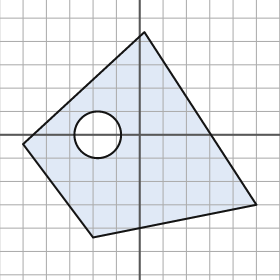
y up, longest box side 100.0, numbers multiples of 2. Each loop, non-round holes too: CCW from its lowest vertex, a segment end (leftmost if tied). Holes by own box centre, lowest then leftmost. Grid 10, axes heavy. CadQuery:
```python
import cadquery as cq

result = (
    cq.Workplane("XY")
    .moveTo(-20.0, -44.0)
    .lineTo(50.0, -30.0)
    .lineTo(2.0, 44.0)
    .lineTo(-50.0, -4.0)
    .close()
    .moveTo(-18.0, 0.0)
    .circle(10.0)
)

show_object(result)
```